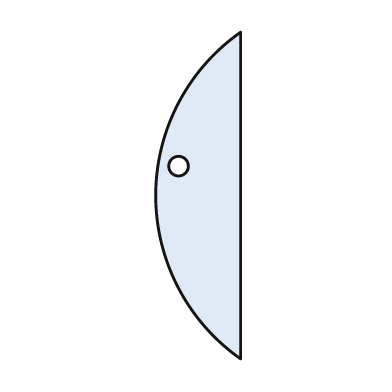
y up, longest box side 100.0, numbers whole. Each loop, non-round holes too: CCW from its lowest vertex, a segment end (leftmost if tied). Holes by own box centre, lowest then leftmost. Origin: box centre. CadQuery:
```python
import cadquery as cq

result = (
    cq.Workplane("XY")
    .moveTo(13.0, -50.0)
    .lineTo(13.0, 50.0)
    .threePointArc((-13.0, 0.0), (13.0, -50.0))
    .close()
    .moveTo(-6.0, 9.0)
    .circle(3.0)
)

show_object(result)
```